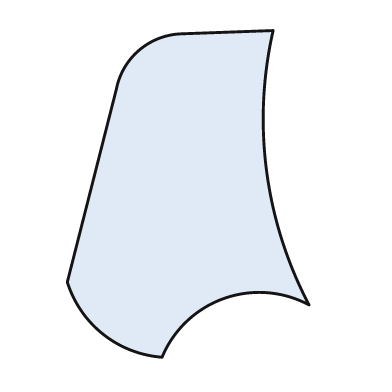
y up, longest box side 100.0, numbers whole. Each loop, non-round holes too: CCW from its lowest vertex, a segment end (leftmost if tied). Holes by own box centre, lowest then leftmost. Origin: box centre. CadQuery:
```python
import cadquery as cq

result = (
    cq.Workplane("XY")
    .moveTo(-8.0, -50.0)
    .threePointArc((11.0, -32.0), (37.0, -34.0))
    .threePointArc((24.0, 7.0), (26.0, 50.0))
    .lineTo(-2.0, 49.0)
    .threePointArc((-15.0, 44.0), (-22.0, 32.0))
    .lineTo(-37.0, -27.0)
    .threePointArc((-26.0, -43.0), (-8.0, -50.0))
    .close()
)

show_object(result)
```